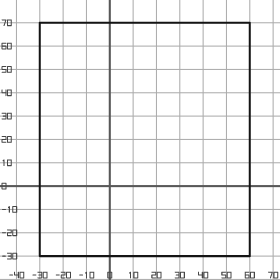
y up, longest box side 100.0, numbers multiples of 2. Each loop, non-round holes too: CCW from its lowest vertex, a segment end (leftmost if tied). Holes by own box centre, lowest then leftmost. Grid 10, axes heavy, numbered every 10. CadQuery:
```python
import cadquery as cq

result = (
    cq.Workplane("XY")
    .moveTo(-30.0, -30.0)
    .lineTo(60.0, -30.0)
    .lineTo(60.0, 70.0)
    .lineTo(-30.0, 70.0)
    .close()
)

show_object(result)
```